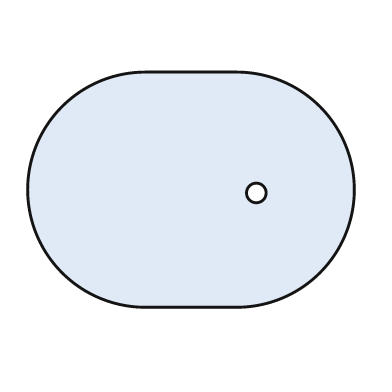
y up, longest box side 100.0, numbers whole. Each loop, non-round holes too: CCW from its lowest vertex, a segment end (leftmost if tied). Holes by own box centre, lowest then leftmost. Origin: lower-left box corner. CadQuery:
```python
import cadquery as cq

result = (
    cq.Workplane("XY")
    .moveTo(36.0, 0.0)
    .lineTo(64.0, 0.0)
    .threePointArc((100.0, 36.0), (64.0, 72.0))
    .lineTo(36.0, 72.0)
    .threePointArc((0.0, 36.0), (36.0, 0.0))
    .close()
    .moveTo(70.0, 35.0)
    .circle(3.0)
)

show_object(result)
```